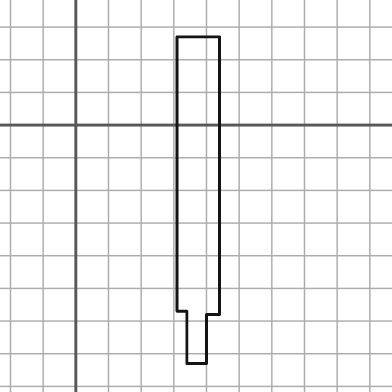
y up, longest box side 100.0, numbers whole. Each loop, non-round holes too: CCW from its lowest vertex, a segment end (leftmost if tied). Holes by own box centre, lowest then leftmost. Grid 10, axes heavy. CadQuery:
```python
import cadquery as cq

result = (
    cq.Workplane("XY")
    .moveTo(34.0, -73.0)
    .lineTo(40.0, -73.0)
    .lineTo(40.0, -58.0)
    .lineTo(44.0, -58.0)
    .lineTo(44.0, 27.0)
    .lineTo(31.0, 27.0)
    .lineTo(31.0, -57.0)
    .lineTo(34.0, -57.0)
    .close()
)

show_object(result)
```